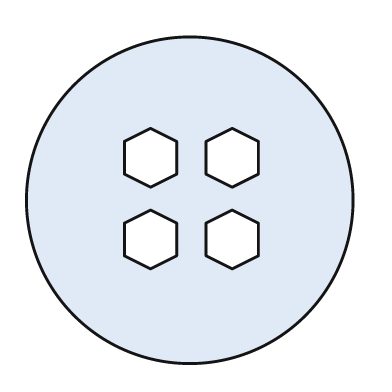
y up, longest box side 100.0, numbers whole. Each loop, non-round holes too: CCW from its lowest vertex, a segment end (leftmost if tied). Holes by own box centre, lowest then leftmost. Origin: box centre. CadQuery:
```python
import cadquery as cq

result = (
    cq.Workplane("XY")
    .moveTo(0.0, 0.0)
    .circle(50.0)
    .moveTo(-12.0, -21.0)
    .lineTo(-4.0, -17.0)
    .lineTo(-4.0, -7.0)
    .lineTo(-12.0, -3.0)
    .lineTo(-20.0, -7.0)
    .lineTo(-20.0, -17.0)
    .close()
    .moveTo(13.0, -21.0)
    .lineTo(21.0, -17.0)
    .lineTo(21.0, -7.0)
    .lineTo(13.0, -3.0)
    .lineTo(5.0, -7.0)
    .lineTo(5.0, -17.0)
    .close()
    .moveTo(-12.0, 4.0)
    .lineTo(-4.0, 8.0)
    .lineTo(-4.0, 18.0)
    .lineTo(-12.0, 22.0)
    .lineTo(-20.0, 18.0)
    .lineTo(-20.0, 8.0)
    .close()
    .moveTo(13.0, 4.0)
    .lineTo(21.0, 8.0)
    .lineTo(21.0, 18.0)
    .lineTo(13.0, 22.0)
    .lineTo(5.0, 18.0)
    .lineTo(5.0, 8.0)
    .close()
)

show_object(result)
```